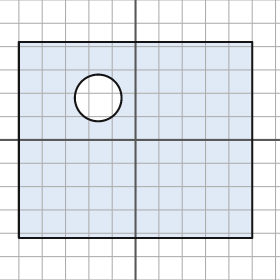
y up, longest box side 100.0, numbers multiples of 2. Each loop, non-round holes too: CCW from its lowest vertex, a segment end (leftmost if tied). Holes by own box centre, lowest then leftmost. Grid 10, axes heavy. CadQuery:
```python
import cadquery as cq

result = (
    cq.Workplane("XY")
    .moveTo(-50.0, -42.0)
    .lineTo(50.0, -42.0)
    .lineTo(50.0, 42.0)
    .lineTo(-50.0, 42.0)
    .close()
    .moveTo(-16.0, 18.0)
    .circle(10.0)
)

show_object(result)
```